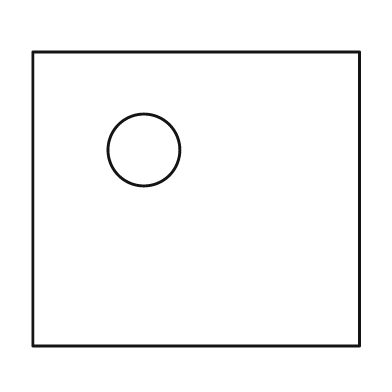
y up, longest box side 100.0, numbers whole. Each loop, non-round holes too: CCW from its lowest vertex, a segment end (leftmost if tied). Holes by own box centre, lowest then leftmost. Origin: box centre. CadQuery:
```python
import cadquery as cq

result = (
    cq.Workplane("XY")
    .moveTo(-50.0, -45.0)
    .lineTo(50.0, -45.0)
    .lineTo(50.0, 45.0)
    .lineTo(-50.0, 45.0)
    .close()
    .moveTo(-16.0, 15.0)
    .circle(11.0)
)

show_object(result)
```